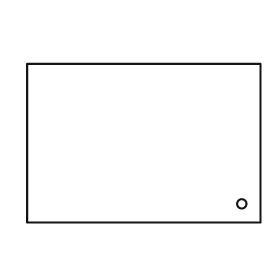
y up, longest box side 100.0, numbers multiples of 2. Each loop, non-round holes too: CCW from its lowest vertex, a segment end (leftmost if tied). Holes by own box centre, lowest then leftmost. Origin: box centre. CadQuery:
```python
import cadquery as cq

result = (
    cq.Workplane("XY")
    .moveTo(-50.0, -34.0)
    .lineTo(50.0, -34.0)
    .lineTo(50.0, 34.0)
    .lineTo(-50.0, 34.0)
    .close()
    .moveTo(42.0, -26.0)
    .circle(2.0)
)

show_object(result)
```